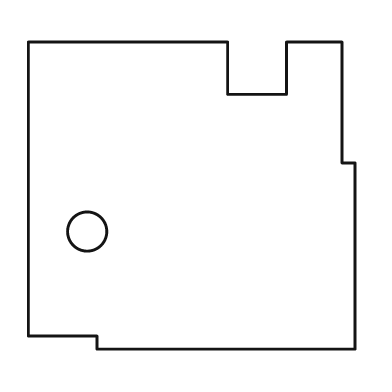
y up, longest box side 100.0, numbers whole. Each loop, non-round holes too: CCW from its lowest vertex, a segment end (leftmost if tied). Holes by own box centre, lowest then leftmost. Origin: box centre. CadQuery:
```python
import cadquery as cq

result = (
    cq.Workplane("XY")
    .moveTo(-29.0, -47.0)
    .lineTo(50.0, -47.0)
    .lineTo(50.0, 10.0)
    .lineTo(46.0, 10.0)
    .lineTo(46.0, 47.0)
    .lineTo(29.0, 47.0)
    .lineTo(29.0, 31.0)
    .lineTo(11.0, 31.0)
    .lineTo(11.0, 47.0)
    .lineTo(-50.0, 47.0)
    .lineTo(-50.0, -43.0)
    .lineTo(-29.0, -43.0)
    .close()
    .moveTo(-32.0, -11.0)
    .circle(6.0)
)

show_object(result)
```